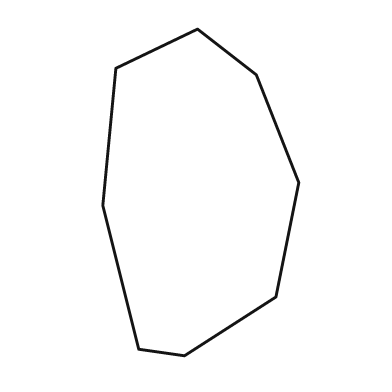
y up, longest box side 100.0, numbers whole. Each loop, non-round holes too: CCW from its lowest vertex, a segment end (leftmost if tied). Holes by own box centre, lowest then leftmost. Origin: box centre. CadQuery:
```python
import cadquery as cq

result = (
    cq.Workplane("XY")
    .moveTo(-5.0, -50.0)
    .lineTo(23.0, -32.0)
    .lineTo(30.0, 3.0)
    .lineTo(17.0, 36.0)
    .lineTo(-1.0, 50.0)
    .lineTo(-26.0, 38.0)
    .lineTo(-30.0, -4.0)
    .lineTo(-19.0, -48.0)
    .close()
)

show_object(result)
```